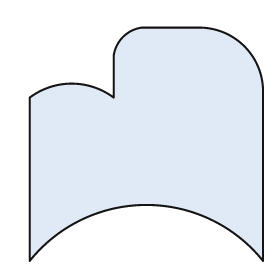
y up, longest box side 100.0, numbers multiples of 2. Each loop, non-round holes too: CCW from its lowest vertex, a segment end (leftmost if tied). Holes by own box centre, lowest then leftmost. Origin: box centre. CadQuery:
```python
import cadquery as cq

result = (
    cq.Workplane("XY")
    .moveTo(-50.0, -50.0)
    .threePointArc((0.0, -26.0), (50.0, -50.0))
    .lineTo(50.0, 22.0)
    .threePointArc((42.0, 42.0), (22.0, 50.0))
    .lineTo(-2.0, 50.0)
    .threePointArc((-10.0, 46.0), (-14.0, 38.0))
    .lineTo(-14.0, 20.0)
    .threePointArc((-32.0, 26.0), (-50.0, 20.0))
    .close()
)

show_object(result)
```